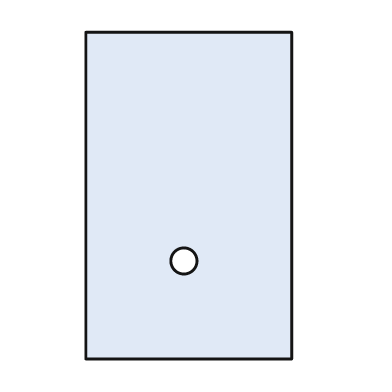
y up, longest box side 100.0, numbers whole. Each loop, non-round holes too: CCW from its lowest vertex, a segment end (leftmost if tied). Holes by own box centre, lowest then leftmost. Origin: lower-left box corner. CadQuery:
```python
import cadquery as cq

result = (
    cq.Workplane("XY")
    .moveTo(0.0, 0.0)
    .lineTo(63.0, 0.0)
    .lineTo(63.0, 100.0)
    .lineTo(0.0, 100.0)
    .close()
    .moveTo(30.0, 30.0)
    .circle(4.0)
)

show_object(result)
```